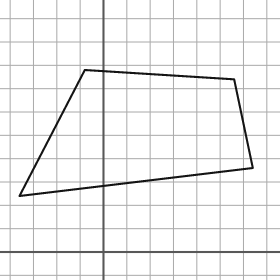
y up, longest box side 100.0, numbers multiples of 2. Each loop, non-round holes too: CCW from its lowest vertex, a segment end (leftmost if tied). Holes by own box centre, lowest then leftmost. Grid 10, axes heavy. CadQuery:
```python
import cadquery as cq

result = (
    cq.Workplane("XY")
    .moveTo(-36.0, 24.0)
    .lineTo(64.0, 36.0)
    .lineTo(56.0, 74.0)
    .lineTo(-8.0, 78.0)
    .close()
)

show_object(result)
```